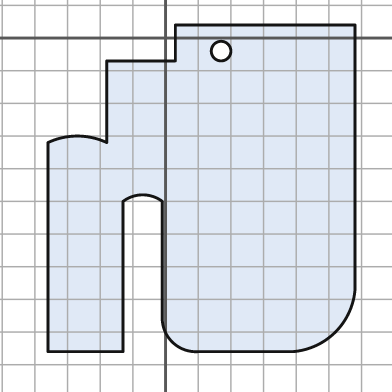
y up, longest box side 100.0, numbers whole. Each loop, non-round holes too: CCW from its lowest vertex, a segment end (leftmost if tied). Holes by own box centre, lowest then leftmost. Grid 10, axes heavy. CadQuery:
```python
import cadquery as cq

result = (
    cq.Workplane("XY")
    .moveTo(-36.0, -96.0)
    .lineTo(-13.0, -96.0)
    .lineTo(-13.0, -50.0)
    .threePointArc((-7.0, -48.0), (-1.0, -50.0))
    .lineTo(-1.0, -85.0)
    .threePointArc((2.0, -93.0), (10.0, -96.0))
    .lineTo(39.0, -96.0)
    .threePointArc((52.0, -90.0), (58.0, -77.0))
    .lineTo(58.0, 4.0)
    .lineTo(3.0, 4.0)
    .lineTo(3.0, -7.0)
    .lineTo(-18.0, -7.0)
    .lineTo(-18.0, -32.0)
    .threePointArc((-27.0, -30.0), (-36.0, -32.0))
    .close()
    .moveTo(17.0, -4.0)
    .circle(3.0)
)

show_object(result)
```